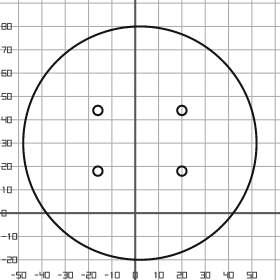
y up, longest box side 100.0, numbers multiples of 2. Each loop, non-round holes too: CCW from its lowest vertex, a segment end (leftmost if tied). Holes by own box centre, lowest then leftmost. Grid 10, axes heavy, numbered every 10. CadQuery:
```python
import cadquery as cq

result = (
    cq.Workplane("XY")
    .moveTo(2.0, 30.0)
    .circle(50.0)
    .moveTo(-16.0, 18.0)
    .circle(2.0)
    .moveTo(20.0, 18.0)
    .circle(2.0)
    .moveTo(-16.0, 44.0)
    .circle(2.0)
    .moveTo(20.0, 44.0)
    .circle(2.0)
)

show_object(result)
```